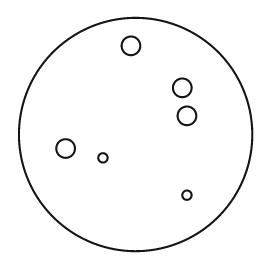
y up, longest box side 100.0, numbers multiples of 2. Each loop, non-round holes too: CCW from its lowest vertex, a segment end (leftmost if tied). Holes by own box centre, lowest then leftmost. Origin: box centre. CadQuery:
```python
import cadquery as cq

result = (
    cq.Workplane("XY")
    .moveTo(0.0, 0.0)
    .circle(50.0)
    .moveTo(22.0, -26.0)
    .circle(2.0)
    .moveTo(-14.0, -10.0)
    .circle(2.0)
    .moveTo(-30.0, -6.0)
    .circle(4.0)
    .moveTo(22.0, 8.0)
    .circle(4.0)
    .moveTo(20.0, 20.0)
    .circle(4.0)
    .moveTo(-2.0, 38.0)
    .circle(4.0)
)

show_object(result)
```